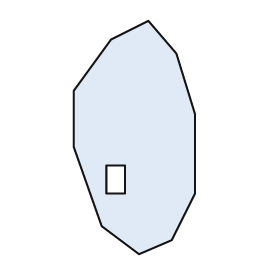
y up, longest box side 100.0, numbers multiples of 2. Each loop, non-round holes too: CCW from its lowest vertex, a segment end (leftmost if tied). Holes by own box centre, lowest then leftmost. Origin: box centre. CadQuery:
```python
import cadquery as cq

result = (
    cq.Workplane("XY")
    .moveTo(2.0, -50.0)
    .lineTo(16.0, -44.0)
    .lineTo(26.0, -24.0)
    .lineTo(26.0, 10.0)
    .lineTo(18.0, 36.0)
    .lineTo(6.0, 50.0)
    .lineTo(-10.0, 42.0)
    .lineTo(-26.0, 20.0)
    .lineTo(-26.0, -4.0)
    .lineTo(-14.0, -38.0)
    .close()
    .moveTo(-12.0, -24.0)
    .lineTo(-4.0, -24.0)
    .lineTo(-4.0, -12.0)
    .lineTo(-12.0, -12.0)
    .close()
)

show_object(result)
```